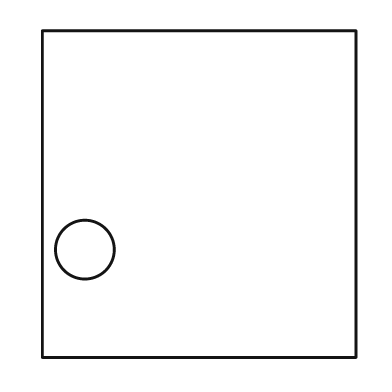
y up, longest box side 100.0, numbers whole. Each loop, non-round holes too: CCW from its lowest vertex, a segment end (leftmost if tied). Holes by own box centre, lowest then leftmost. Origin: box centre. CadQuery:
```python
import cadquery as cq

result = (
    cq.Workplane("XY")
    .moveTo(-48.0, -50.0)
    .lineTo(48.0, -50.0)
    .lineTo(48.0, 50.0)
    .lineTo(-48.0, 50.0)
    .close()
    .moveTo(-35.0, -17.0)
    .circle(9.0)
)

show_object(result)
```